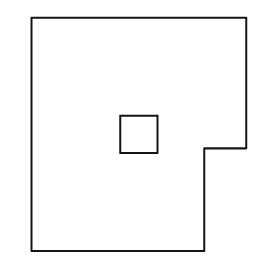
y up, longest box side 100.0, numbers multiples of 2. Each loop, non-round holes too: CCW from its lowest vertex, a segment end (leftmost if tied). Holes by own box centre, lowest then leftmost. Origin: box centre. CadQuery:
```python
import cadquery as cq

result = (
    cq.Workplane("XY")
    .moveTo(-46.0, -50.0)
    .lineTo(28.0, -50.0)
    .lineTo(28.0, -6.0)
    .lineTo(46.0, -6.0)
    .lineTo(46.0, 50.0)
    .lineTo(-46.0, 50.0)
    .close()
    .moveTo(-8.0, -8.0)
    .lineTo(8.0, -8.0)
    .lineTo(8.0, 8.0)
    .lineTo(-8.0, 8.0)
    .close()
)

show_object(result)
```